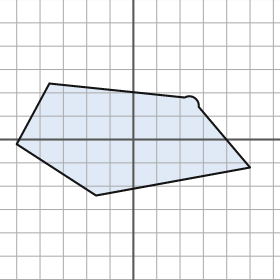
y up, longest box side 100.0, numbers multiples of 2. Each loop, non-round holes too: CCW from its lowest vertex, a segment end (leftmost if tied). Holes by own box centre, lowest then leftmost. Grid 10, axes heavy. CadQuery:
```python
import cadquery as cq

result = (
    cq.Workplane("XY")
    .moveTo(-16.0, -24.0)
    .lineTo(50.0, -12.0)
    .lineTo(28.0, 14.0)
    .threePointArc((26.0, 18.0), (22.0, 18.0))
    .lineTo(-36.0, 24.0)
    .lineTo(-50.0, -2.0)
    .close()
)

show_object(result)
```